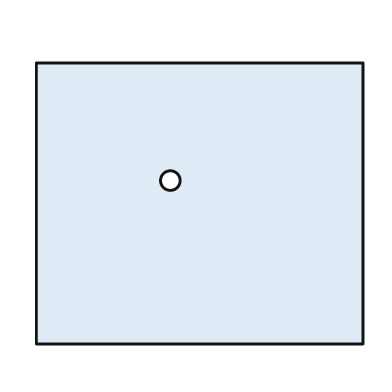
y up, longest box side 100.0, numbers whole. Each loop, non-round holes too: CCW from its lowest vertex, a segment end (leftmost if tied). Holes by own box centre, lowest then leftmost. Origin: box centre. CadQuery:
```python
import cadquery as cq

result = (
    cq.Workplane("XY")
    .moveTo(-50.0, -43.0)
    .lineTo(50.0, -43.0)
    .lineTo(50.0, 43.0)
    .lineTo(-50.0, 43.0)
    .close()
    .moveTo(-9.0, 7.0)
    .circle(3.0)
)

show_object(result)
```